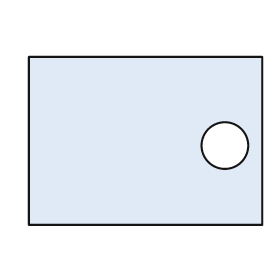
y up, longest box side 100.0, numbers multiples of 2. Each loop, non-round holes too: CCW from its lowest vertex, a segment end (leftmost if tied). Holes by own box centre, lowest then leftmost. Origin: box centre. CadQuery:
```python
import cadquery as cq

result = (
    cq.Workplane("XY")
    .moveTo(-50.0, -36.0)
    .lineTo(50.0, -36.0)
    .lineTo(50.0, 36.0)
    .lineTo(-50.0, 36.0)
    .close()
    .moveTo(34.0, -2.0)
    .circle(10.0)
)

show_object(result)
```